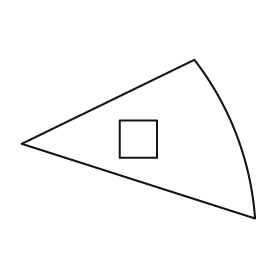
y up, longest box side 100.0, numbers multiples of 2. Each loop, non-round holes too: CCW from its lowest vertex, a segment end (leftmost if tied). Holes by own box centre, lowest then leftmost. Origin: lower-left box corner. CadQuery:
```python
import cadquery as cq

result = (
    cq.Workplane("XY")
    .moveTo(100.0, 0.0)
    .threePointArc((92.0, 36.0), (74.0, 68.0))
    .lineTo(0.0, 32.0)
    .close()
    .moveTo(42.0, 26.0)
    .lineTo(58.0, 26.0)
    .lineTo(58.0, 42.0)
    .lineTo(42.0, 42.0)
    .close()
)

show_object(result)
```